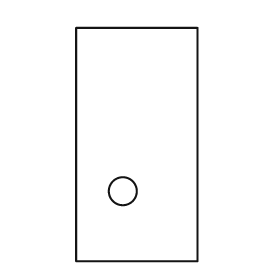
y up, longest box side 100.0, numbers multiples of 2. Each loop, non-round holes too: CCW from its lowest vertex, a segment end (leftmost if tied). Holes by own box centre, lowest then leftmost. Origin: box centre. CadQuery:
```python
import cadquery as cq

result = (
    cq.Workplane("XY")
    .moveTo(-26.0, -50.0)
    .lineTo(26.0, -50.0)
    .lineTo(26.0, 50.0)
    .lineTo(-26.0, 50.0)
    .close()
    .moveTo(-6.0, -20.0)
    .circle(6.0)
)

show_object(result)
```